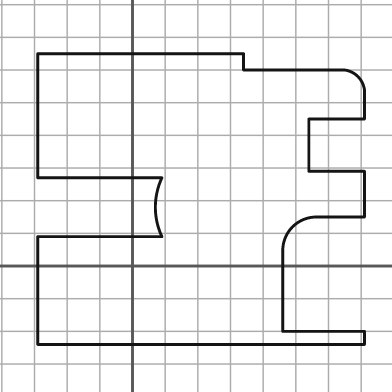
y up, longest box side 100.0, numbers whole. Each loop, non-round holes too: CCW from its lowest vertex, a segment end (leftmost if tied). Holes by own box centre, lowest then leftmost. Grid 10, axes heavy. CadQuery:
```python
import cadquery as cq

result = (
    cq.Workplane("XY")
    .moveTo(-29.0, -24.0)
    .lineTo(71.0, -24.0)
    .lineTo(71.0, -20.0)
    .lineTo(46.0, -20.0)
    .lineTo(46.0, 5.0)
    .threePointArc((49.0, 12.0), (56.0, 15.0))
    .lineTo(71.0, 15.0)
    .lineTo(71.0, 29.0)
    .lineTo(54.0, 29.0)
    .lineTo(54.0, 45.0)
    .lineTo(71.0, 45.0)
    .lineTo(71.0, 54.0)
    .threePointArc((69.0, 58.0), (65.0, 60.0))
    .lineTo(34.0, 60.0)
    .lineTo(34.0, 65.0)
    .lineTo(-29.0, 65.0)
    .lineTo(-29.0, 27.0)
    .lineTo(9.0, 27.0)
    .threePointArc((7.0, 18.0), (9.0, 9.0))
    .lineTo(-29.0, 9.0)
    .close()
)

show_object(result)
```